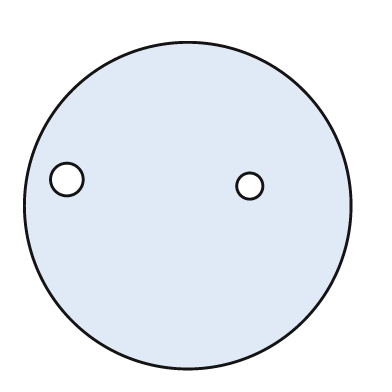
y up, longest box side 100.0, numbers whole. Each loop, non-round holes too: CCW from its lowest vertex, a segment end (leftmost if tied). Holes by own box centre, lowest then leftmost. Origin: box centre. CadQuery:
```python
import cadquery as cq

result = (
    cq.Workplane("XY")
    .moveTo(0.0, 0.0)
    .circle(50.0)
    .moveTo(19.0, 6.0)
    .circle(4.0)
    .moveTo(-37.0, 8.0)
    .circle(5.0)
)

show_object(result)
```